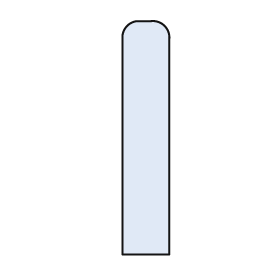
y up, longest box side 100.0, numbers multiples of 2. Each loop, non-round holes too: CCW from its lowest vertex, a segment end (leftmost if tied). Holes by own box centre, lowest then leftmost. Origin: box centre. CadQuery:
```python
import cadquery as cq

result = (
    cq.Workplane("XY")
    .moveTo(-10.0, -50.0)
    .lineTo(10.0, -50.0)
    .lineTo(10.0, 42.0)
    .threePointArc((8.0, 48.0), (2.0, 50.0))
    .lineTo(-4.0, 50.0)
    .threePointArc((-8.0, 48.0), (-10.0, 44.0))
    .close()
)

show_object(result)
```